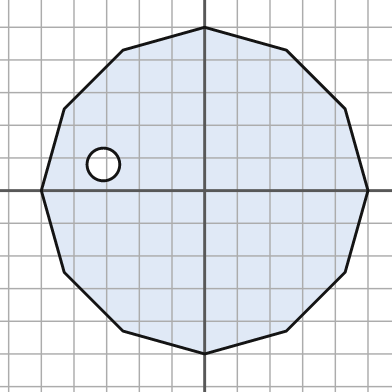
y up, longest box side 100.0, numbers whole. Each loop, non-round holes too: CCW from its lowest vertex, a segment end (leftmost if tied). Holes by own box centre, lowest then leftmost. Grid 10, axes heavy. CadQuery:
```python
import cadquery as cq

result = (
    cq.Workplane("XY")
    .moveTo(0.0, -50.0)
    .lineTo(25.0, -43.0)
    .lineTo(43.0, -25.0)
    .lineTo(50.0, 0.0)
    .lineTo(43.0, 25.0)
    .lineTo(25.0, 43.0)
    .lineTo(0.0, 50.0)
    .lineTo(-25.0, 43.0)
    .lineTo(-43.0, 25.0)
    .lineTo(-50.0, 0.0)
    .lineTo(-43.0, -25.0)
    .lineTo(-25.0, -43.0)
    .close()
    .moveTo(-31.0, 8.0)
    .circle(5.0)
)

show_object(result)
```